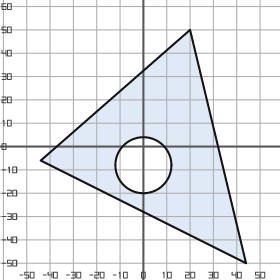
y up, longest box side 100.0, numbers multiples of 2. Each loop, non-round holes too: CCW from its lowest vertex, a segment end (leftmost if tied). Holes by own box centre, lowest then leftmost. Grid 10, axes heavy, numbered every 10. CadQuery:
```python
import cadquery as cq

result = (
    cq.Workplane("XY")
    .moveTo(44.0, -50.0)
    .lineTo(20.0, 50.0)
    .lineTo(-44.0, -6.0)
    .close()
    .moveTo(0.0, -8.0)
    .circle(12.0)
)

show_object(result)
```